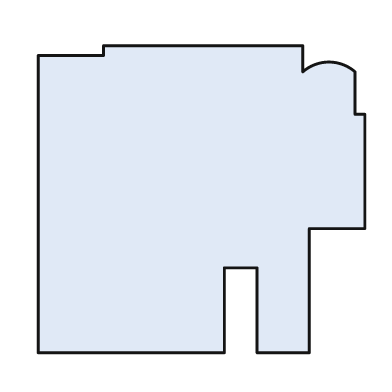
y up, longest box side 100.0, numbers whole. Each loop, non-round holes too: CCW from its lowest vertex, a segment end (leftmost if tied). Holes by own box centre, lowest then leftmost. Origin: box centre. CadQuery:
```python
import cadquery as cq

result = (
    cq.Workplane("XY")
    .moveTo(-50.0, -47.0)
    .lineTo(7.0, -47.0)
    .lineTo(7.0, -21.0)
    .lineTo(17.0, -21.0)
    .lineTo(17.0, -47.0)
    .lineTo(33.0, -47.0)
    .lineTo(33.0, -9.0)
    .lineTo(50.0, -9.0)
    .lineTo(50.0, 26.0)
    .lineTo(47.0, 26.0)
    .lineTo(47.0, 39.0)
    .threePointArc((39.0, 42.0), (31.0, 39.0))
    .lineTo(31.0, 47.0)
    .lineTo(-30.0, 47.0)
    .lineTo(-30.0, 44.0)
    .lineTo(-50.0, 44.0)
    .close()
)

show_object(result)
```